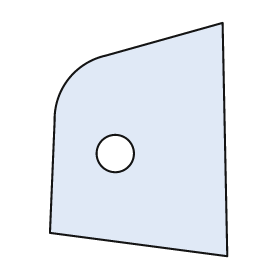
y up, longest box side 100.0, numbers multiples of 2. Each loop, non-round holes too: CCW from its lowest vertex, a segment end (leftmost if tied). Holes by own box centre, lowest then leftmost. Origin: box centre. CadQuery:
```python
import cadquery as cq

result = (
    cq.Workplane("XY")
    .moveTo(38.0, -50.0)
    .lineTo(36.0, 50.0)
    .lineTo(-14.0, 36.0)
    .threePointArc((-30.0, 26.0), (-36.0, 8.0))
    .lineTo(-38.0, -40.0)
    .close()
    .moveTo(-10.0, -6.0)
    .circle(8.0)
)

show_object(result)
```